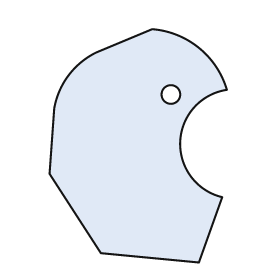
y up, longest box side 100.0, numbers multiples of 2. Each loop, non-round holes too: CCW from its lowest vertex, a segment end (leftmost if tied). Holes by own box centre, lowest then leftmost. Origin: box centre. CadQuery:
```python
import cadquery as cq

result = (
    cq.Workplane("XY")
    .moveTo(26.0, -50.0)
    .lineTo(36.0, -22.0)
    .threePointArc((18.0, 2.0), (38.0, 24.0))
    .threePointArc((26.0, 42.0), (6.0, 50.0))
    .lineTo(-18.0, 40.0)
    .threePointArc((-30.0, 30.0), (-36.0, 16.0))
    .lineTo(-38.0, -12.0)
    .lineTo(-16.0, -46.0)
    .close()
    .moveTo(14.0, 22.0)
    .circle(4.0)
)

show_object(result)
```